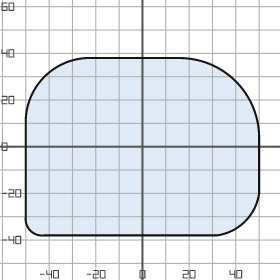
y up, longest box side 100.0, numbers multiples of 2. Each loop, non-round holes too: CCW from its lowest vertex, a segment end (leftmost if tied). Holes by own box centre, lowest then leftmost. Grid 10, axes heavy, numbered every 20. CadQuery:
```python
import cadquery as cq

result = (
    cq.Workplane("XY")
    .moveTo(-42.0, -38.0)
    .lineTo(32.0, -38.0)
    .threePointArc((44.0, -32.0), (50.0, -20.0))
    .lineTo(50.0, 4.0)
    .threePointArc((40.0, 28.0), (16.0, 38.0))
    .lineTo(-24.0, 38.0)
    .threePointArc((-42.0, 30.0), (-50.0, 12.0))
    .lineTo(-50.0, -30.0)
    .threePointArc((-48.0, -36.0), (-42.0, -38.0))
    .close()
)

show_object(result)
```